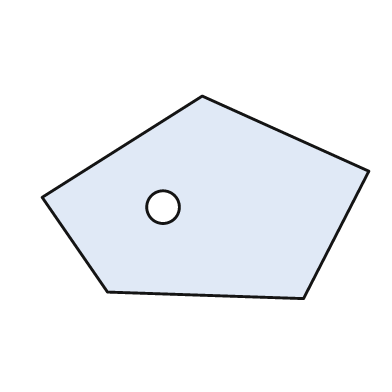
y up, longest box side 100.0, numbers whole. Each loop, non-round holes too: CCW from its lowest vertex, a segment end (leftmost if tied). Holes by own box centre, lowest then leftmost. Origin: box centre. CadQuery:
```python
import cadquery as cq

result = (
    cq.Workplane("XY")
    .moveTo(30.0, -31.0)
    .lineTo(50.0, 8.0)
    .lineTo(-1.0, 31.0)
    .lineTo(-50.0, 0.0)
    .lineTo(-30.0, -29.0)
    .close()
    .moveTo(-13.0, -3.0)
    .circle(5.0)
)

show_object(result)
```